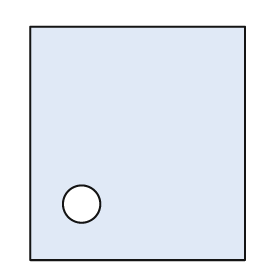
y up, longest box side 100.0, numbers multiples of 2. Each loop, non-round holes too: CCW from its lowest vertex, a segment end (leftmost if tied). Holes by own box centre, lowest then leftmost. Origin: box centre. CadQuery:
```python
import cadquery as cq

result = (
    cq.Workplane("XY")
    .moveTo(-46.0, -50.0)
    .lineTo(46.0, -50.0)
    .lineTo(46.0, 50.0)
    .lineTo(-46.0, 50.0)
    .close()
    .moveTo(-24.0, -26.0)
    .circle(8.0)
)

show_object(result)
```